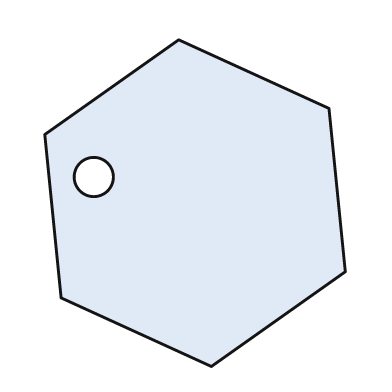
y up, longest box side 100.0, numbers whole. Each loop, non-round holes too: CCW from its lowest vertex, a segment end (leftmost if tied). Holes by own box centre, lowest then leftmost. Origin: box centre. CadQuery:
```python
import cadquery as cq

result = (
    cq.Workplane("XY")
    .moveTo(5.0, -50.0)
    .lineTo(46.0, -21.0)
    .lineTo(41.0, 29.0)
    .lineTo(-5.0, 50.0)
    .lineTo(-46.0, 21.0)
    .lineTo(-41.0, -29.0)
    .close()
    .moveTo(-31.0, 8.0)
    .circle(6.0)
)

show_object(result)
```